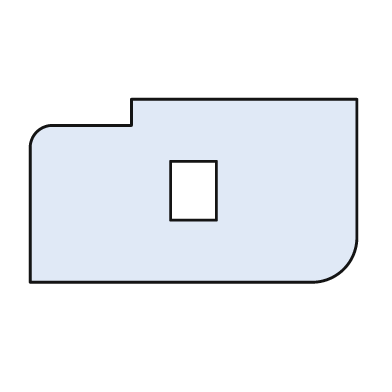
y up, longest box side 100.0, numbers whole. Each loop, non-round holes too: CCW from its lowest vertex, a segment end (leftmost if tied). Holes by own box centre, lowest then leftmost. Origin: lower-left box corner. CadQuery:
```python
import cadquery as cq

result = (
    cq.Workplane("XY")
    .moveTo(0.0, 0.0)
    .lineTo(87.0, 0.0)
    .threePointArc((96.0, 4.0), (100.0, 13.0))
    .lineTo(100.0, 56.0)
    .lineTo(31.0, 56.0)
    .lineTo(31.0, 48.0)
    .lineTo(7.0, 48.0)
    .threePointArc((2.0, 46.0), (0.0, 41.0))
    .close()
    .moveTo(43.0, 19.0)
    .lineTo(57.0, 19.0)
    .lineTo(57.0, 37.0)
    .lineTo(43.0, 37.0)
    .close()
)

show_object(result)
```